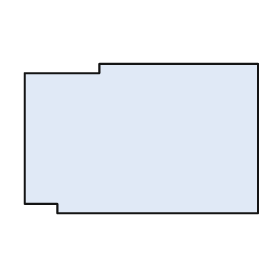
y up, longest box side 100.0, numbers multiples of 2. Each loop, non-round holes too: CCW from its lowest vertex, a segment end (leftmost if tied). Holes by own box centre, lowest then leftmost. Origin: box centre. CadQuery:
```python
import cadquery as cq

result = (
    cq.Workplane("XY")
    .moveTo(-36.0, -32.0)
    .lineTo(50.0, -32.0)
    .lineTo(50.0, 32.0)
    .lineTo(-18.0, 32.0)
    .lineTo(-18.0, 28.0)
    .lineTo(-50.0, 28.0)
    .lineTo(-50.0, -28.0)
    .lineTo(-36.0, -28.0)
    .close()
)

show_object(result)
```